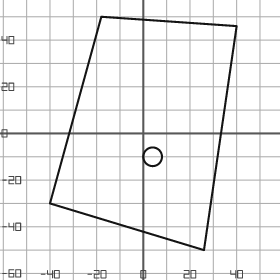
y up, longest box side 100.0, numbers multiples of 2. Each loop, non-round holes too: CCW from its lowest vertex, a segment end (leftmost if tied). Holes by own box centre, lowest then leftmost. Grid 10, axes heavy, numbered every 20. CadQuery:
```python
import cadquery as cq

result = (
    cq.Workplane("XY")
    .moveTo(26.0, -50.0)
    .lineTo(40.0, 46.0)
    .lineTo(-18.0, 50.0)
    .lineTo(-40.0, -30.0)
    .close()
    .moveTo(4.0, -10.0)
    .circle(4.0)
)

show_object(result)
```